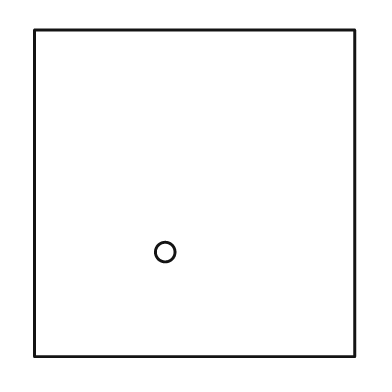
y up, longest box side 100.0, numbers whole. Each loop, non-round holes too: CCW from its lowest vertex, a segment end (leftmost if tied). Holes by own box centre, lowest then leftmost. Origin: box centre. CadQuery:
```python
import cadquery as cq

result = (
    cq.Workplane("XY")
    .moveTo(-49.0, -50.0)
    .lineTo(49.0, -50.0)
    .lineTo(49.0, 50.0)
    .lineTo(-49.0, 50.0)
    .close()
    .moveTo(-9.0, -18.0)
    .circle(3.0)
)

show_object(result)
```